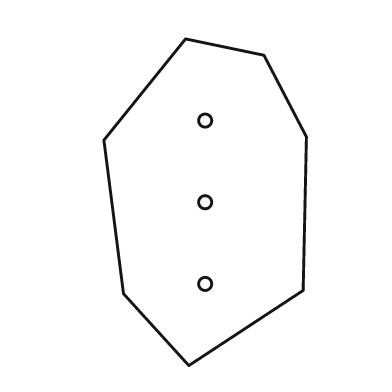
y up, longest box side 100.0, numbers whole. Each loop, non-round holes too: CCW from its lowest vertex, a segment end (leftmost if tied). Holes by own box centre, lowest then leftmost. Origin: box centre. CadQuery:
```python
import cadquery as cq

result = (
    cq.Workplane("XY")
    .moveTo(-5.0, -50.0)
    .lineTo(30.0, -27.0)
    .lineTo(31.0, 20.0)
    .lineTo(18.0, 45.0)
    .lineTo(-6.0, 50.0)
    .lineTo(-31.0, 19.0)
    .lineTo(-25.0, -28.0)
    .close()
    .moveTo(0.0, -25.0)
    .circle(2.0)
    .moveTo(0.0, 0.0)
    .circle(2.0)
    .moveTo(0.0, 25.0)
    .circle(2.0)
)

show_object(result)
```